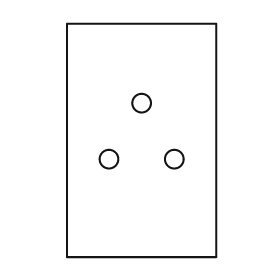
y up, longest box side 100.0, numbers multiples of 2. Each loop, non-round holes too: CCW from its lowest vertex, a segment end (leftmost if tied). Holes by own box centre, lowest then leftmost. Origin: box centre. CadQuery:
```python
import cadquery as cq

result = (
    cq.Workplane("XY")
    .moveTo(-32.0, -50.0)
    .lineTo(32.0, -50.0)
    .lineTo(32.0, 50.0)
    .lineTo(-32.0, 50.0)
    .close()
    .moveTo(-14.0, -8.0)
    .circle(4.0)
    .moveTo(14.0, -8.0)
    .circle(4.0)
    .moveTo(0.0, 16.0)
    .circle(4.0)
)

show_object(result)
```